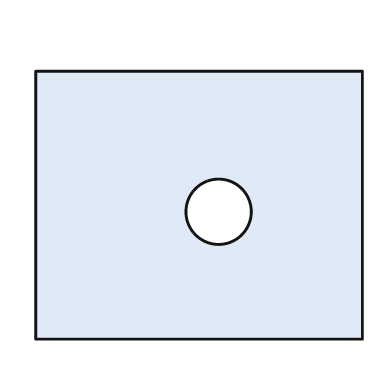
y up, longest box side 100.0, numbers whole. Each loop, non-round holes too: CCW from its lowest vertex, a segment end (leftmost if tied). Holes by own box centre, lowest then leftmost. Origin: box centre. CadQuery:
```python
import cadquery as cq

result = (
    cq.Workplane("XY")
    .moveTo(-50.0, -41.0)
    .lineTo(50.0, -41.0)
    .lineTo(50.0, 41.0)
    .lineTo(-50.0, 41.0)
    .close()
    .moveTo(6.0, -2.0)
    .circle(10.0)
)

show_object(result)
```